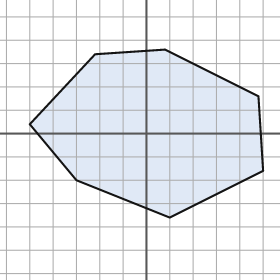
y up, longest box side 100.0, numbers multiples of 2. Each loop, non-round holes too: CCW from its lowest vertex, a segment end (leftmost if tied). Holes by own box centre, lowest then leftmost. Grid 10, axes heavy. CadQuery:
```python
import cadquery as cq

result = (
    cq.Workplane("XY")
    .moveTo(10.0, -36.0)
    .lineTo(50.0, -16.0)
    .lineTo(48.0, 16.0)
    .lineTo(8.0, 36.0)
    .lineTo(-22.0, 34.0)
    .lineTo(-50.0, 4.0)
    .lineTo(-30.0, -20.0)
    .close()
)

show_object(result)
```